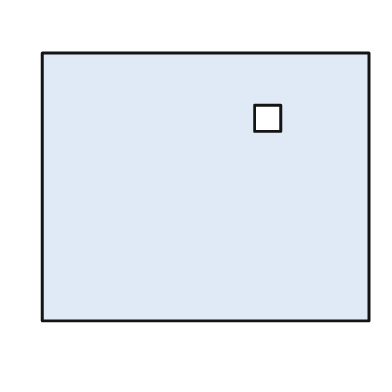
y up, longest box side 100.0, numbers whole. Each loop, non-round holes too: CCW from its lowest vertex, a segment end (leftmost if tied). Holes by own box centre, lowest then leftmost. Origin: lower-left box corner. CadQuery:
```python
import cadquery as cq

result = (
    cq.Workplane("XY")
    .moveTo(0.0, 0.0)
    .lineTo(100.0, 0.0)
    .lineTo(100.0, 82.0)
    .lineTo(0.0, 82.0)
    .close()
    .moveTo(65.0, 58.0)
    .lineTo(73.0, 58.0)
    .lineTo(73.0, 66.0)
    .lineTo(65.0, 66.0)
    .close()
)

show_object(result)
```